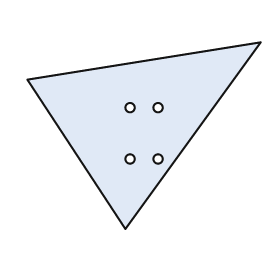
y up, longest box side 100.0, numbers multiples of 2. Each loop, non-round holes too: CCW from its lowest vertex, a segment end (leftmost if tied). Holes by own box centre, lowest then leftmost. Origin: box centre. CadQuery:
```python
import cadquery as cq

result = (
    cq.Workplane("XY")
    .moveTo(-8.0, -40.0)
    .lineTo(50.0, 40.0)
    .lineTo(-50.0, 24.0)
    .close()
    .moveTo(-6.0, -10.0)
    .circle(2.0)
    .moveTo(6.0, -10.0)
    .circle(2.0)
    .moveTo(-6.0, 12.0)
    .circle(2.0)
    .moveTo(6.0, 12.0)
    .circle(2.0)
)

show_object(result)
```